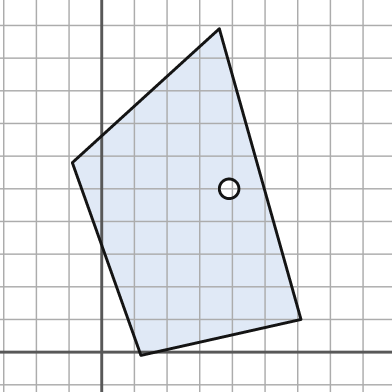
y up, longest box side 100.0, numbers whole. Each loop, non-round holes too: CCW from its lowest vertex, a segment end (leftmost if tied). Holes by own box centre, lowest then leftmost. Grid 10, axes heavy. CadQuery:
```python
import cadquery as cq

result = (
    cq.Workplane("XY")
    .moveTo(12.0, -1.0)
    .lineTo(61.0, 10.0)
    .lineTo(36.0, 99.0)
    .lineTo(-9.0, 58.0)
    .close()
    .moveTo(39.0, 50.0)
    .circle(3.0)
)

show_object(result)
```